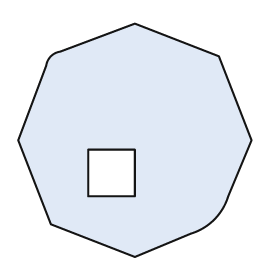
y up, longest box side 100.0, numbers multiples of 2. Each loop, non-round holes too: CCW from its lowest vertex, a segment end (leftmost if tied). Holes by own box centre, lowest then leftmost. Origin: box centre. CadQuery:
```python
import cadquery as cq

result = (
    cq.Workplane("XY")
    .moveTo(0.0, -50.0)
    .lineTo(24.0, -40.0)
    .threePointArc((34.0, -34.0), (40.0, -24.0))
    .lineTo(50.0, 0.0)
    .lineTo(36.0, 36.0)
    .lineTo(0.0, 50.0)
    .lineTo(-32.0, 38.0)
    .threePointArc((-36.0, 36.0), (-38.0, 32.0))
    .lineTo(-50.0, 0.0)
    .lineTo(-36.0, -36.0)
    .close()
    .moveTo(-20.0, -24.0)
    .lineTo(0.0, -24.0)
    .lineTo(0.0, -4.0)
    .lineTo(-20.0, -4.0)
    .close()
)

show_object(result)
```